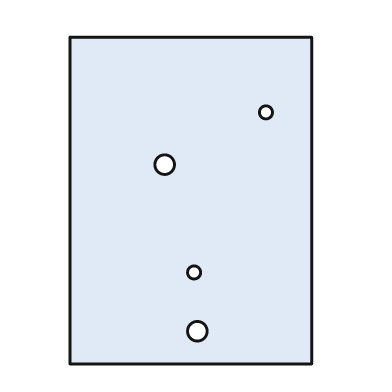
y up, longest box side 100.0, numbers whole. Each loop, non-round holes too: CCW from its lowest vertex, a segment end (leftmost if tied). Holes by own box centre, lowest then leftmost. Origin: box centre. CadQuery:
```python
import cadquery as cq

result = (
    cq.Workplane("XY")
    .moveTo(-37.0, -50.0)
    .lineTo(37.0, -50.0)
    .lineTo(37.0, 50.0)
    .lineTo(-37.0, 50.0)
    .close()
    .moveTo(2.0, -40.0)
    .circle(3.0)
    .moveTo(1.0, -22.0)
    .circle(2.0)
    .moveTo(-8.0, 11.0)
    .circle(3.0)
    .moveTo(23.0, 27.0)
    .circle(2.0)
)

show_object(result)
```